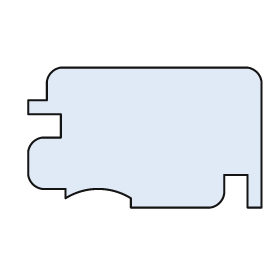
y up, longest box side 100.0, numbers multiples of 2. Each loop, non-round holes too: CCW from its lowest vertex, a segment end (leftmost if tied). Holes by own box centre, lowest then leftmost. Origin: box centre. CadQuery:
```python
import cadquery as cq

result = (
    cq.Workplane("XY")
    .moveTo(-6.0, -30.0)
    .lineTo(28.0, -30.0)
    .threePointArc((32.0, -28.0), (34.0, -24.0))
    .lineTo(34.0, -16.0)
    .lineTo(44.0, -16.0)
    .lineTo(44.0, -30.0)
    .lineTo(50.0, -30.0)
    .lineTo(50.0, 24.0)
    .threePointArc((48.0, 28.0), (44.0, 30.0))
    .lineTo(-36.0, 30.0)
    .threePointArc((-40.0, 28.0), (-42.0, 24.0))
    .lineTo(-42.0, 16.0)
    .lineTo(-50.0, 16.0)
    .lineTo(-50.0, 10.0)
    .lineTo(-36.0, 10.0)
    .lineTo(-36.0, 0.0)
    .lineTo(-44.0, 0.0)
    .threePointArc((-48.0, -2.0), (-50.0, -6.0))
    .lineTo(-50.0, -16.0)
    .threePointArc((-48.0, -20.0), (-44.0, -22.0))
    .lineTo(-34.0, -22.0)
    .lineTo(-34.0, -26.0)
    .threePointArc((-20.0, -22.0), (-6.0, -26.0))
    .close()
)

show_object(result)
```